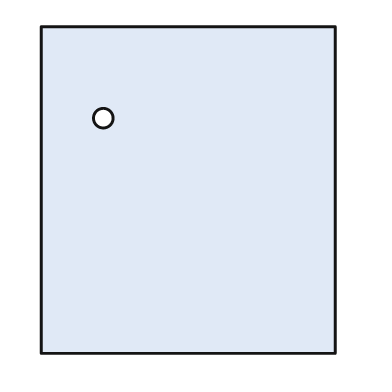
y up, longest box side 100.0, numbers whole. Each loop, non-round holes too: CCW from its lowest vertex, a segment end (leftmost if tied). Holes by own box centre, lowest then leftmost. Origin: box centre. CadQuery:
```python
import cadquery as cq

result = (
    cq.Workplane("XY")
    .moveTo(-45.0, -50.0)
    .lineTo(45.0, -50.0)
    .lineTo(45.0, 50.0)
    .lineTo(-45.0, 50.0)
    .close()
    .moveTo(-26.0, 22.0)
    .circle(3.0)
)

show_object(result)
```